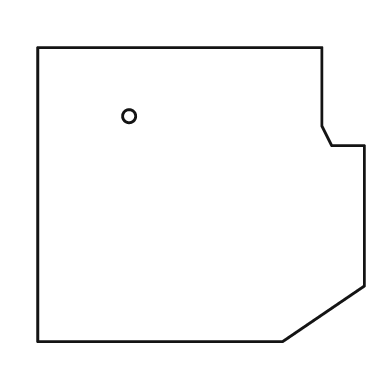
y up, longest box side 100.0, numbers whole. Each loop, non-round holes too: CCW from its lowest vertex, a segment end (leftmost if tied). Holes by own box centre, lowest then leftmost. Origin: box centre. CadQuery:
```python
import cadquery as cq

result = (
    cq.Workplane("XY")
    .moveTo(-50.0, -45.0)
    .lineTo(25.0, -45.0)
    .lineTo(50.0, -28.0)
    .lineTo(50.0, 15.0)
    .lineTo(40.0, 15.0)
    .lineTo(37.0, 21.0)
    .lineTo(37.0, 45.0)
    .lineTo(-50.0, 45.0)
    .close()
    .moveTo(-22.0, 24.0)
    .circle(2.0)
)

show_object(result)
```